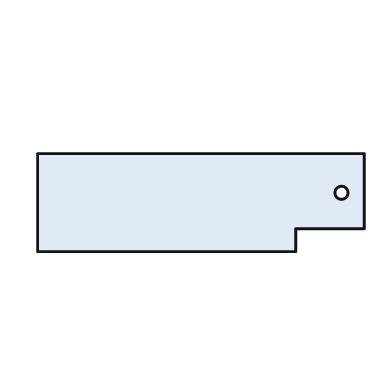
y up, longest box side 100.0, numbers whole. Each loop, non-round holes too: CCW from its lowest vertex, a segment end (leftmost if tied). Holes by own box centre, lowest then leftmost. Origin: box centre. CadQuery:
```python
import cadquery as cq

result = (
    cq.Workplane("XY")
    .moveTo(-50.0, -15.0)
    .lineTo(29.0, -15.0)
    .lineTo(29.0, -8.0)
    .lineTo(50.0, -8.0)
    .lineTo(50.0, 15.0)
    .lineTo(-50.0, 15.0)
    .close()
    .moveTo(43.0, 3.0)
    .circle(2.0)
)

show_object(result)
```